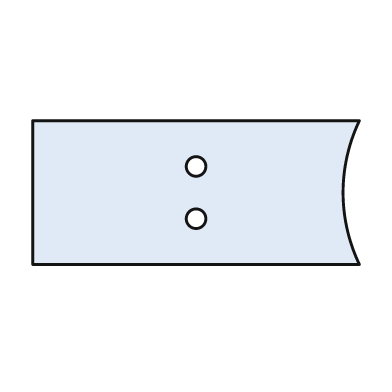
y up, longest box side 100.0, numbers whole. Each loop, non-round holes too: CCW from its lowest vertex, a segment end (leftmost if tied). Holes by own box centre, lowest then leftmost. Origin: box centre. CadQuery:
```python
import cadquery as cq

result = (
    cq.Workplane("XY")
    .moveTo(-50.0, -22.0)
    .lineTo(50.0, -22.0)
    .threePointArc((45.0, 0.0), (50.0, 22.0))
    .lineTo(-50.0, 22.0)
    .close()
    .moveTo(0.0, -8.0)
    .circle(3.0)
    .moveTo(0.0, 8.0)
    .circle(3.0)
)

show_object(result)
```